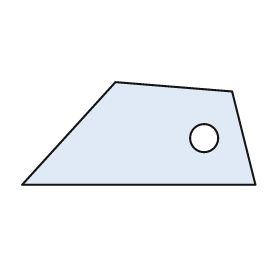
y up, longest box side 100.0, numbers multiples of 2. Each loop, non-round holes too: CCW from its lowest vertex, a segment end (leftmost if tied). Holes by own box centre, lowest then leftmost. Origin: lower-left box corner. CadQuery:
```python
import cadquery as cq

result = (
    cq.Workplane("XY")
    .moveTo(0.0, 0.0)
    .lineTo(100.0, 0.0)
    .lineTo(90.0, 40.0)
    .lineTo(40.0, 44.0)
    .close()
    .moveTo(78.0, 20.0)
    .circle(6.0)
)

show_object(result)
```